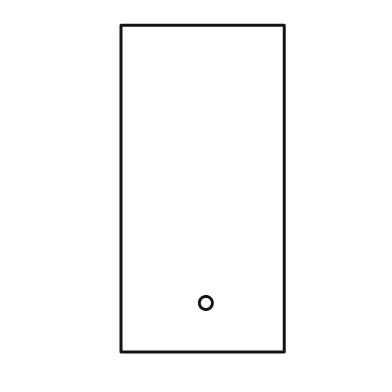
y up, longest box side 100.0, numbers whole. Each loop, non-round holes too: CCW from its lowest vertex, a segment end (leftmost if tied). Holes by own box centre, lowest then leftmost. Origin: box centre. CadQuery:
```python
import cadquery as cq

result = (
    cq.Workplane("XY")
    .moveTo(-25.0, -50.0)
    .lineTo(25.0, -50.0)
    .lineTo(25.0, 50.0)
    .lineTo(-25.0, 50.0)
    .close()
    .moveTo(1.0, -35.0)
    .circle(2.0)
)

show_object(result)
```